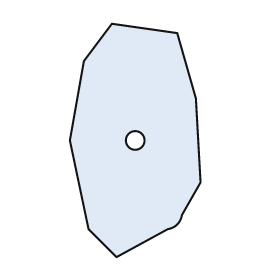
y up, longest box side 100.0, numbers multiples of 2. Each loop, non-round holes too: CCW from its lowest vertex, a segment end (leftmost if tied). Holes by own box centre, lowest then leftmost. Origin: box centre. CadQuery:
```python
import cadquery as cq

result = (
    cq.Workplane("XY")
    .moveTo(-8.0, -50.0)
    .lineTo(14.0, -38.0)
    .threePointArc((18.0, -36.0), (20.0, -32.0))
    .lineTo(28.0, -18.0)
    .lineTo(26.0, 18.0)
    .lineTo(18.0, 46.0)
    .lineTo(-10.0, 50.0)
    .lineTo(-22.0, 34.0)
    .lineTo(-28.0, 0.0)
    .lineTo(-20.0, -38.0)
    .close()
    .moveTo(0.0, 0.0)
    .circle(4.0)
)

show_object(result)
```